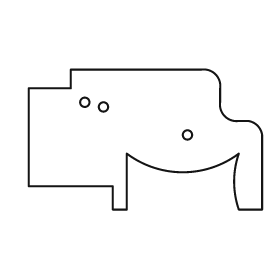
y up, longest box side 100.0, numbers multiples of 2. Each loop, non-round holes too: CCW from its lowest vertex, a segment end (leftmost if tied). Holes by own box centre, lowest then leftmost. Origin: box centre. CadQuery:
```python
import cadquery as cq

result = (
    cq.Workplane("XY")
    .moveTo(-14.0, -30.0)
    .lineTo(-8.0, -30.0)
    .lineTo(-8.0, -6.0)
    .threePointArc((16.0, -14.0), (40.0, -6.0))
    .threePointArc((38.0, -18.0), (40.0, -30.0))
    .lineTo(50.0, -30.0)
    .lineTo(50.0, 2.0)
    .threePointArc((48.0, 6.0), (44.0, 8.0))
    .lineTo(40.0, 8.0)
    .threePointArc((34.0, 10.0), (32.0, 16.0))
    .lineTo(32.0, 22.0)
    .threePointArc((30.0, 28.0), (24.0, 30.0))
    .lineTo(-32.0, 30.0)
    .lineTo(-32.0, 22.0)
    .lineTo(-50.0, 22.0)
    .lineTo(-50.0, -20.0)
    .lineTo(-14.0, -20.0)
    .close()
    .moveTo(18.0, 2.0)
    .circle(2.0)
    .moveTo(-18.0, 14.0)
    .circle(2.0)
    .moveTo(-26.0, 16.0)
    .circle(2.0)
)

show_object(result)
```